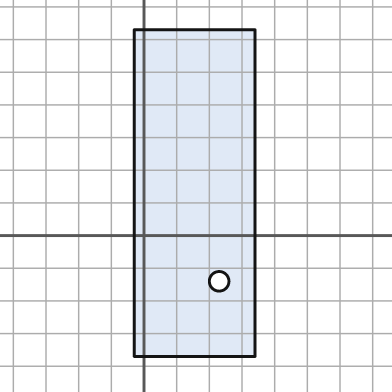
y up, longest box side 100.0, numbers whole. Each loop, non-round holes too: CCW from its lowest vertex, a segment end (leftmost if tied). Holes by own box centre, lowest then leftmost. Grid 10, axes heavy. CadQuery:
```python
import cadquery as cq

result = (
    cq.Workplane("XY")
    .moveTo(-3.0, -37.0)
    .lineTo(34.0, -37.0)
    .lineTo(34.0, 63.0)
    .lineTo(-3.0, 63.0)
    .close()
    .moveTo(23.0, -14.0)
    .circle(3.0)
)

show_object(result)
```